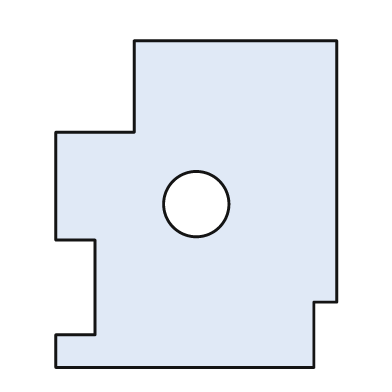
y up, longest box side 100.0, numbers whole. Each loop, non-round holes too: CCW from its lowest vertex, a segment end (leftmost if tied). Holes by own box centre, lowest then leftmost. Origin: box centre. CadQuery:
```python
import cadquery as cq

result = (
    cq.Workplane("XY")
    .moveTo(-43.0, -50.0)
    .lineTo(36.0, -50.0)
    .lineTo(36.0, -30.0)
    .lineTo(43.0, -30.0)
    .lineTo(43.0, 50.0)
    .lineTo(-19.0, 50.0)
    .lineTo(-19.0, 22.0)
    .lineTo(-43.0, 22.0)
    .lineTo(-43.0, -11.0)
    .lineTo(-31.0, -11.0)
    .lineTo(-31.0, -40.0)
    .lineTo(-43.0, -40.0)
    .close()
    .moveTo(0.0, 0.0)
    .circle(10.0)
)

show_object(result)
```